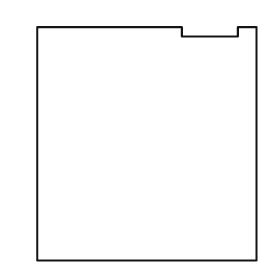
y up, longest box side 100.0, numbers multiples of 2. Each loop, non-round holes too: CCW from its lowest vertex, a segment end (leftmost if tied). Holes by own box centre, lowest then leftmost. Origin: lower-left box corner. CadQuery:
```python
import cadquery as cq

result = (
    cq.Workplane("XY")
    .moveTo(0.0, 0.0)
    .lineTo(94.0, 0.0)
    .lineTo(94.0, 100.0)
    .lineTo(86.0, 100.0)
    .lineTo(86.0, 96.0)
    .lineTo(62.0, 96.0)
    .lineTo(62.0, 100.0)
    .lineTo(0.0, 100.0)
    .close()
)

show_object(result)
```